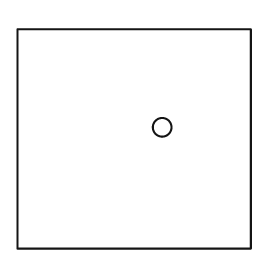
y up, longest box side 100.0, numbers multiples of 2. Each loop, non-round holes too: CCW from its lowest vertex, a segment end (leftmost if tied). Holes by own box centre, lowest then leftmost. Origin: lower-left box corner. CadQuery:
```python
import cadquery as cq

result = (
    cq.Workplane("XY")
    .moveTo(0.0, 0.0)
    .lineTo(100.0, 0.0)
    .lineTo(100.0, 94.0)
    .lineTo(0.0, 94.0)
    .close()
    .moveTo(62.0, 52.0)
    .circle(4.0)
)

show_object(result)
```